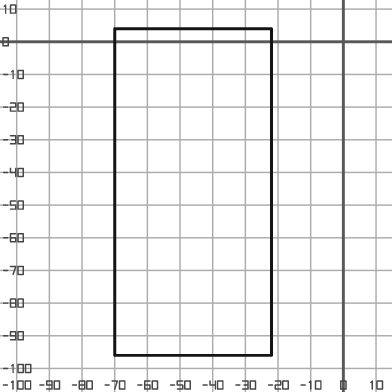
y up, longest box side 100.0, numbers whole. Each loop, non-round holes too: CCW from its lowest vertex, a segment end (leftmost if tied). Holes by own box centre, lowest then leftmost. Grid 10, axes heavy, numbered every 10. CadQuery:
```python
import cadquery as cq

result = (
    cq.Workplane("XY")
    .moveTo(-70.0, -96.0)
    .lineTo(-22.0, -96.0)
    .lineTo(-22.0, 4.0)
    .lineTo(-70.0, 4.0)
    .close()
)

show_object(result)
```